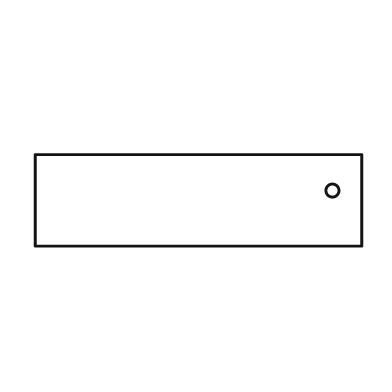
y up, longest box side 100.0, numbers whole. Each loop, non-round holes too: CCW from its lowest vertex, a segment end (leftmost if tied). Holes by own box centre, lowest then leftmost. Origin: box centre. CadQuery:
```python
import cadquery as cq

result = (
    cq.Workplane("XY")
    .moveTo(-50.0, -14.0)
    .lineTo(50.0, -14.0)
    .lineTo(50.0, 14.0)
    .lineTo(-50.0, 14.0)
    .close()
    .moveTo(41.0, 3.0)
    .circle(2.0)
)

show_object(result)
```